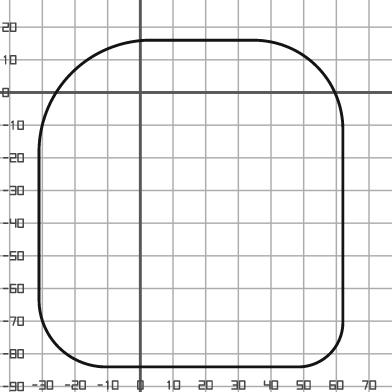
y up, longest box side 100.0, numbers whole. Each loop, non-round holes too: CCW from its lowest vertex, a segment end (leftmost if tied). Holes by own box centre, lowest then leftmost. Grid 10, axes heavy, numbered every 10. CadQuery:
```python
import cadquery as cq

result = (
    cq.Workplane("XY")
    .moveTo(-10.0, -84.0)
    .lineTo(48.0, -84.0)
    .threePointArc((58.0, -80.0), (62.0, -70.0))
    .lineTo(62.0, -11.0)
    .threePointArc((54.0, 8.0), (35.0, 16.0))
    .lineTo(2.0, 16.0)
    .threePointArc((-21.0, 6.0), (-31.0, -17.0))
    .lineTo(-31.0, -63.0)
    .threePointArc((-25.0, -78.0), (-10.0, -84.0))
    .close()
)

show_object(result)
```